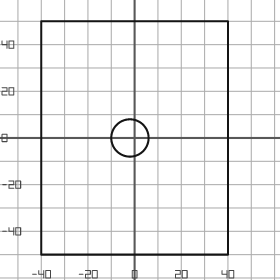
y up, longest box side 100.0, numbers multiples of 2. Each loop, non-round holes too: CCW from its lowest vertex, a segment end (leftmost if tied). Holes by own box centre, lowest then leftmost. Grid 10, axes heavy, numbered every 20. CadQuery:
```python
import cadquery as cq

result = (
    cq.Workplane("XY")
    .moveTo(-40.0, -50.0)
    .lineTo(40.0, -50.0)
    .lineTo(40.0, 50.0)
    .lineTo(-40.0, 50.0)
    .close()
    .moveTo(-2.0, 0.0)
    .circle(8.0)
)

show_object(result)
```